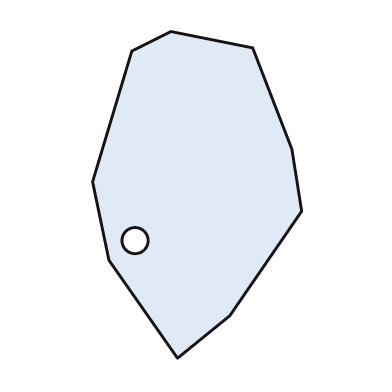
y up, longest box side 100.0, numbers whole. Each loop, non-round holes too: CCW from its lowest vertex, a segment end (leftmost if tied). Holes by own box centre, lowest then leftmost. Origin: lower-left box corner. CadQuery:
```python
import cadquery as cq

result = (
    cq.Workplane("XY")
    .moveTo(26.0, 0.0)
    .lineTo(42.0, 13.0)
    .lineTo(64.0, 45.0)
    .lineTo(61.0, 64.0)
    .lineTo(49.0, 95.0)
    .lineTo(24.0, 100.0)
    .lineTo(12.0, 94.0)
    .lineTo(0.0, 54.0)
    .lineTo(5.0, 30.0)
    .close()
    .moveTo(13.0, 36.0)
    .circle(4.0)
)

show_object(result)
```